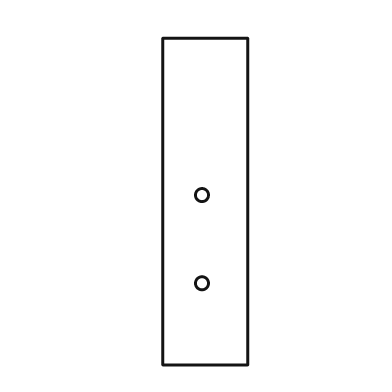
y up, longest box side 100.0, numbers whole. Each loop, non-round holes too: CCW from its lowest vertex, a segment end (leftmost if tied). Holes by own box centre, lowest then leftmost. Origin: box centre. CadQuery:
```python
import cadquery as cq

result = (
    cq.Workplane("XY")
    .moveTo(-13.0, -50.0)
    .lineTo(13.0, -50.0)
    .lineTo(13.0, 50.0)
    .lineTo(-13.0, 50.0)
    .close()
    .moveTo(-1.0, -25.0)
    .circle(2.0)
    .moveTo(-1.0, 2.0)
    .circle(2.0)
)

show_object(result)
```